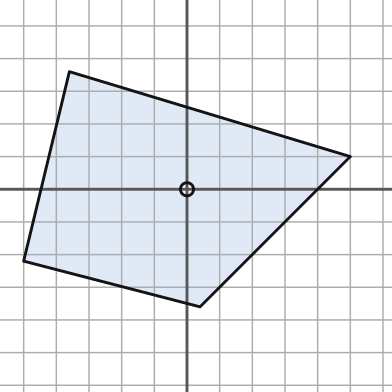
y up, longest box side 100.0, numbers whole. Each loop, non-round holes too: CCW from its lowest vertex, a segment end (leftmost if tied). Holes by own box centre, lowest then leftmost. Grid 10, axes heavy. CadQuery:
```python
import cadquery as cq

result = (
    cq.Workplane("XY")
    .moveTo(4.0, -36.0)
    .lineTo(50.0, 10.0)
    .lineTo(-36.0, 36.0)
    .lineTo(-50.0, -22.0)
    .close()
    .moveTo(0.0, 0.0)
    .circle(2.0)
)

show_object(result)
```